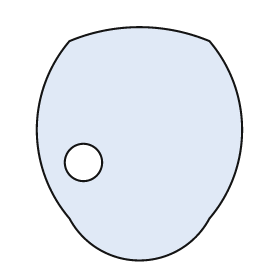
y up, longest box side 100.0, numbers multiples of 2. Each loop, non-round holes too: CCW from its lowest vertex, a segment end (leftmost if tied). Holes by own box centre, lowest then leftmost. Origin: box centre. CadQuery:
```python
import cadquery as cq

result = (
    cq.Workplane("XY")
    .moveTo(-30.0, -32.0)
    .threePointArc((0.0, -50.0), (30.0, -32.0))
    .threePointArc((44.0, 6.0), (30.0, 44.0))
    .threePointArc((0.0, 50.0), (-30.0, 44.0))
    .threePointArc((-44.0, 6.0), (-30.0, -32.0))
    .close()
    .moveTo(-24.0, -8.0)
    .circle(8.0)
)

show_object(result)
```